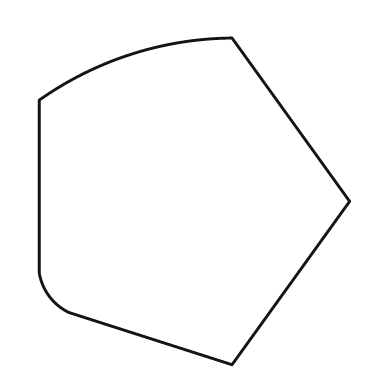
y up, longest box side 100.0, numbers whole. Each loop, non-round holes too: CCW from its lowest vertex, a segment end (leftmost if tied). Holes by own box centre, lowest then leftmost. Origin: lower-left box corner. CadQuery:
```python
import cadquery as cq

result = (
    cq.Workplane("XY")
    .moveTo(59.0, 0.0)
    .lineTo(95.0, 50.0)
    .lineTo(59.0, 100.0)
    .threePointArc((28.0, 95.0), (0.0, 81.0))
    .lineTo(0.0, 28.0)
    .threePointArc((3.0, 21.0), (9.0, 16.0))
    .close()
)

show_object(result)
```